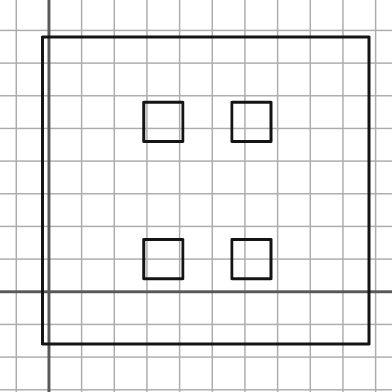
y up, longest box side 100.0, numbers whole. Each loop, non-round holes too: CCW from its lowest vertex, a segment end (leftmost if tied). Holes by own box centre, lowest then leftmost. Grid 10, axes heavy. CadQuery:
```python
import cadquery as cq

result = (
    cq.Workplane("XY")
    .moveTo(-2.0, -16.0)
    .lineTo(98.0, -16.0)
    .lineTo(98.0, 78.0)
    .lineTo(-2.0, 78.0)
    .close()
    .moveTo(29.0, 4.0)
    .lineTo(41.0, 4.0)
    .lineTo(41.0, 16.0)
    .lineTo(29.0, 16.0)
    .close()
    .moveTo(56.0, 4.0)
    .lineTo(68.0, 4.0)
    .lineTo(68.0, 16.0)
    .lineTo(56.0, 16.0)
    .close()
    .moveTo(29.0, 46.0)
    .lineTo(41.0, 46.0)
    .lineTo(41.0, 58.0)
    .lineTo(29.0, 58.0)
    .close()
    .moveTo(56.0, 46.0)
    .lineTo(68.0, 46.0)
    .lineTo(68.0, 58.0)
    .lineTo(56.0, 58.0)
    .close()
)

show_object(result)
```